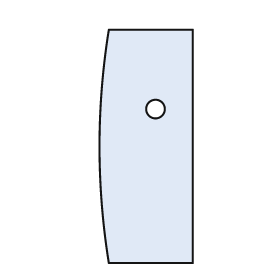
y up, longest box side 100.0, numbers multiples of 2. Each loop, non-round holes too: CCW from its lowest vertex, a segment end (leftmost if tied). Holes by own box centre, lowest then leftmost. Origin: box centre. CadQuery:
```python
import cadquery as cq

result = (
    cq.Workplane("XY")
    .moveTo(-16.0, -50.0)
    .lineTo(20.0, -50.0)
    .lineTo(20.0, 50.0)
    .lineTo(-16.0, 50.0)
    .threePointArc((-20.0, 0.0), (-16.0, -50.0))
    .close()
    .moveTo(4.0, 16.0)
    .circle(4.0)
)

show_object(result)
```